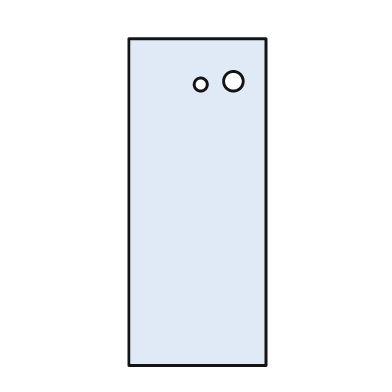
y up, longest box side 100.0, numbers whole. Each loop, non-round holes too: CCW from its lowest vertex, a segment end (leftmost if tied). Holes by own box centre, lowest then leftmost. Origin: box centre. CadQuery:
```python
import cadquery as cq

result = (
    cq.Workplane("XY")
    .moveTo(-21.0, -50.0)
    .lineTo(21.0, -50.0)
    .lineTo(21.0, 50.0)
    .lineTo(-21.0, 50.0)
    .close()
    .moveTo(1.0, 36.0)
    .circle(2.0)
    .moveTo(11.0, 37.0)
    .circle(3.0)
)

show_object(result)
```